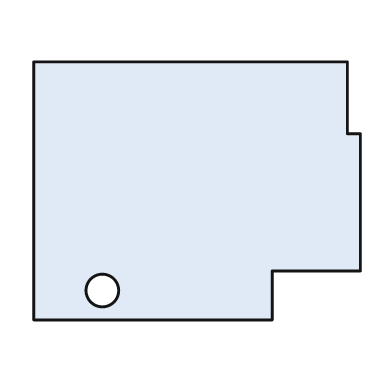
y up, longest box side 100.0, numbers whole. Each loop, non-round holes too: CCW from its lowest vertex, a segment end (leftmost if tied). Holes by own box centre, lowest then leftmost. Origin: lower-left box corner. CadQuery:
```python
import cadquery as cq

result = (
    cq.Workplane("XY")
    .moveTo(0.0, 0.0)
    .lineTo(73.0, 0.0)
    .lineTo(73.0, 15.0)
    .lineTo(100.0, 15.0)
    .lineTo(100.0, 57.0)
    .lineTo(96.0, 57.0)
    .lineTo(96.0, 79.0)
    .lineTo(0.0, 79.0)
    .close()
    .moveTo(21.0, 9.0)
    .circle(5.0)
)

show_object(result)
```